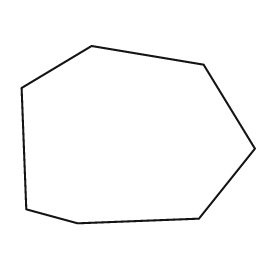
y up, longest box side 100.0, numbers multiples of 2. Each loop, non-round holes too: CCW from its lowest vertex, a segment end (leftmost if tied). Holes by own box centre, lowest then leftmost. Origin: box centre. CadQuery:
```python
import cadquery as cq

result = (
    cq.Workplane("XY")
    .moveTo(-26.0, -38.0)
    .lineTo(26.0, -36.0)
    .lineTo(50.0, -6.0)
    .lineTo(28.0, 30.0)
    .lineTo(-20.0, 38.0)
    .lineTo(-50.0, 20.0)
    .lineTo(-48.0, -32.0)
    .close()
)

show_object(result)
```